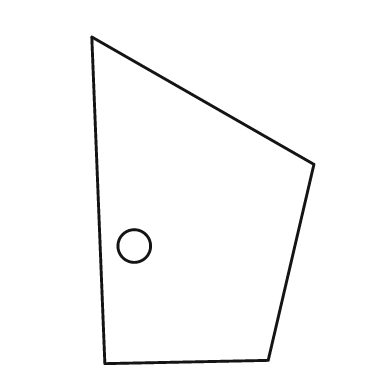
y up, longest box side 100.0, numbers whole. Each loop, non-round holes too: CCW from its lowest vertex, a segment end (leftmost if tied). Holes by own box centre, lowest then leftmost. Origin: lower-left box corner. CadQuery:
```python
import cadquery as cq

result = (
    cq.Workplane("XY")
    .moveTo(4.0, 0.0)
    .lineTo(54.0, 1.0)
    .lineTo(68.0, 61.0)
    .lineTo(0.0, 100.0)
    .close()
    .moveTo(13.0, 36.0)
    .circle(5.0)
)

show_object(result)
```